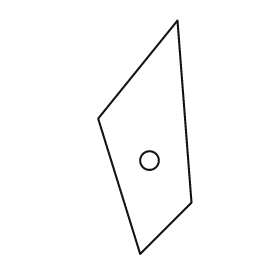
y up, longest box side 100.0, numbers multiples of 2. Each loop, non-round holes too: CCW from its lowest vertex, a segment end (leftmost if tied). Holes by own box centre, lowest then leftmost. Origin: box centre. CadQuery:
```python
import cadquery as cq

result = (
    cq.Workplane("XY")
    .moveTo(-2.0, -50.0)
    .lineTo(20.0, -28.0)
    .lineTo(14.0, 50.0)
    .lineTo(-20.0, 8.0)
    .close()
    .moveTo(2.0, -10.0)
    .circle(4.0)
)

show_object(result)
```